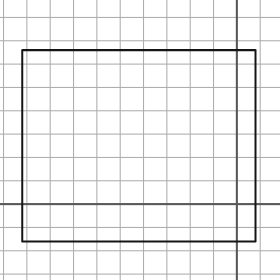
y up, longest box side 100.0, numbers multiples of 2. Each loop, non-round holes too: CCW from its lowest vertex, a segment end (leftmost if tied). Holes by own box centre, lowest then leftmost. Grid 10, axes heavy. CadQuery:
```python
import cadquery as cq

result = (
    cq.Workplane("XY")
    .moveTo(-92.0, -16.0)
    .lineTo(8.0, -16.0)
    .lineTo(8.0, 66.0)
    .lineTo(-92.0, 66.0)
    .close()
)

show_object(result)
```